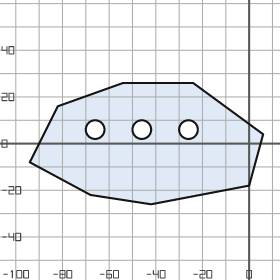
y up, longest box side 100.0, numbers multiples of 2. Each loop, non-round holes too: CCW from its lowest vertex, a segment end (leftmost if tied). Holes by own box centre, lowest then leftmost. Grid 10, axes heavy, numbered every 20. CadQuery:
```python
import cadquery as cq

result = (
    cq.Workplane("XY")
    .moveTo(-42.0, -26.0)
    .lineTo(0.0, -18.0)
    .lineTo(6.0, 4.0)
    .lineTo(-24.0, 26.0)
    .lineTo(-54.0, 26.0)
    .lineTo(-82.0, 16.0)
    .lineTo(-94.0, -8.0)
    .lineTo(-68.0, -22.0)
    .close()
    .moveTo(-66.0, 6.0)
    .circle(4.0)
    .moveTo(-46.0, 6.0)
    .circle(4.0)
    .moveTo(-26.0, 6.0)
    .circle(4.0)
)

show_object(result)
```